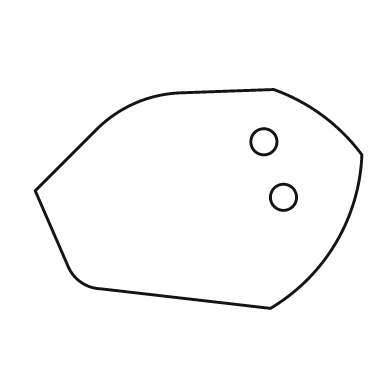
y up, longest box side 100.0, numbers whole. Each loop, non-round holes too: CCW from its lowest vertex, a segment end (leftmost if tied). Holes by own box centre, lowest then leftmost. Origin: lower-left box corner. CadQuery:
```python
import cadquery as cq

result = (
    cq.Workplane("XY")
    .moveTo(72.0, 0.0)
    .threePointArc((92.0, 20.0), (100.0, 47.0))
    .threePointArc((88.0, 59.0), (73.0, 67.0))
    .lineTo(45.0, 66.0)
    .threePointArc((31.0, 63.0), (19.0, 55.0))
    .lineTo(0.0, 36.0)
    .lineTo(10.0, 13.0)
    .threePointArc((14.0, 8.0), (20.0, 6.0))
    .close()
    .moveTo(76.0, 34.0)
    .circle(4.0)
    .moveTo(70.0, 51.0)
    .circle(4.0)
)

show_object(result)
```